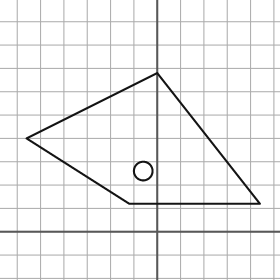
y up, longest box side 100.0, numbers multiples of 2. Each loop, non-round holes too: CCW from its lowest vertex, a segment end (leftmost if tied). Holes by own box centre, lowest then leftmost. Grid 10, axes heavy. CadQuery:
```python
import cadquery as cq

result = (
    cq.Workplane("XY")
    .moveTo(-12.0, 12.0)
    .lineTo(44.0, 12.0)
    .lineTo(0.0, 68.0)
    .lineTo(-56.0, 40.0)
    .close()
    .moveTo(-6.0, 26.0)
    .circle(4.0)
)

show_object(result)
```